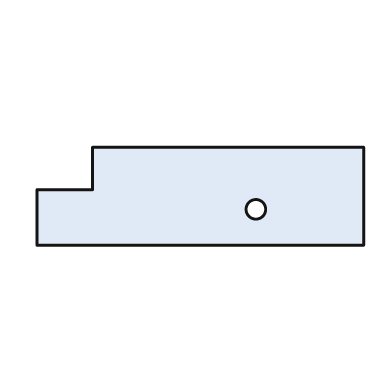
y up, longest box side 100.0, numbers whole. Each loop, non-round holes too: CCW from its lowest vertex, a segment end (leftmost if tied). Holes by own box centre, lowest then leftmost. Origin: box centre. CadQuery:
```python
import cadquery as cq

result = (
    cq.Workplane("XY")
    .moveTo(-50.0, -15.0)
    .lineTo(50.0, -15.0)
    .lineTo(50.0, 15.0)
    .lineTo(-33.0, 15.0)
    .lineTo(-33.0, 2.0)
    .lineTo(-50.0, 2.0)
    .close()
    .moveTo(17.0, -4.0)
    .circle(3.0)
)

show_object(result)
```